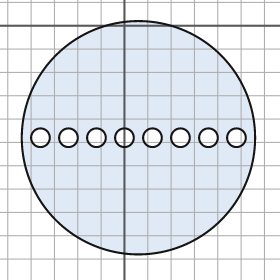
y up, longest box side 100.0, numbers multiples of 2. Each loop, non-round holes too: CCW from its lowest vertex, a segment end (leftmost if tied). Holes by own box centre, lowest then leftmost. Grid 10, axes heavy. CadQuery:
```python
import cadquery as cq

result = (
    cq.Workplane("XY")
    .moveTo(6.0, -48.0)
    .circle(50.0)
    .moveTo(-36.0, -48.0)
    .circle(4.0)
    .moveTo(-24.0, -48.0)
    .circle(4.0)
    .moveTo(-12.0, -48.0)
    .circle(4.0)
    .moveTo(0.0, -48.0)
    .circle(4.0)
    .moveTo(12.0, -48.0)
    .circle(4.0)
    .moveTo(24.0, -48.0)
    .circle(4.0)
    .moveTo(36.0, -48.0)
    .circle(4.0)
    .moveTo(48.0, -48.0)
    .circle(4.0)
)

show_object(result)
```